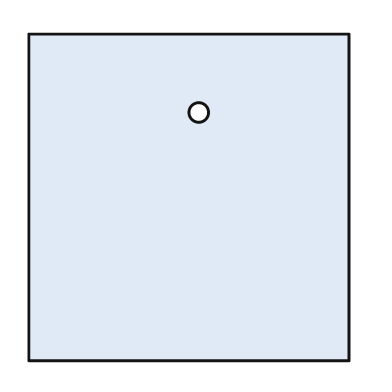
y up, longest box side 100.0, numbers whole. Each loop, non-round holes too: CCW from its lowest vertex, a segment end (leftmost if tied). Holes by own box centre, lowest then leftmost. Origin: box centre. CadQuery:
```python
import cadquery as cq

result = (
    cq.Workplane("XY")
    .moveTo(-49.0, -50.0)
    .lineTo(49.0, -50.0)
    .lineTo(49.0, 50.0)
    .lineTo(-49.0, 50.0)
    .close()
    .moveTo(3.0, 26.0)
    .circle(3.0)
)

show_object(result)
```